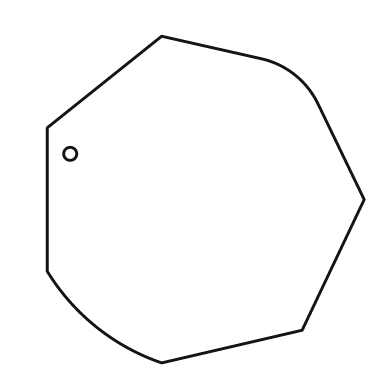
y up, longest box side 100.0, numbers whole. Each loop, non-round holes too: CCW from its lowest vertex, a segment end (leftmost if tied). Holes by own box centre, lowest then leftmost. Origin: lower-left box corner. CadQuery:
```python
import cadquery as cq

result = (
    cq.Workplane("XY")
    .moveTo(35.0, 0.0)
    .lineTo(78.0, 10.0)
    .lineTo(97.0, 50.0)
    .lineTo(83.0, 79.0)
    .threePointArc((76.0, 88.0), (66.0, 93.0))
    .lineTo(35.0, 100.0)
    .lineTo(0.0, 72.0)
    .lineTo(0.0, 28.0)
    .threePointArc((15.0, 11.0), (35.0, 0.0))
    .close()
    .moveTo(7.0, 64.0)
    .circle(2.0)
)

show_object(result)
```